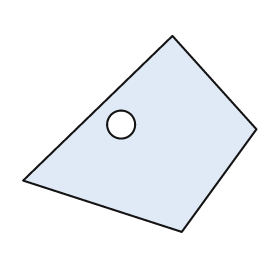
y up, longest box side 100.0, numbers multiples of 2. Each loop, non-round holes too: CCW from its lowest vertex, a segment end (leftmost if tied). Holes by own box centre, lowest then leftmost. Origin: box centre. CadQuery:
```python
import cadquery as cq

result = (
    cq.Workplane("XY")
    .moveTo(18.0, -42.0)
    .lineTo(50.0, 2.0)
    .lineTo(14.0, 42.0)
    .lineTo(-50.0, -20.0)
    .close()
    .moveTo(-8.0, 4.0)
    .circle(6.0)
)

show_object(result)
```